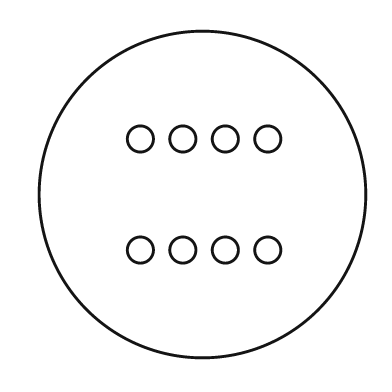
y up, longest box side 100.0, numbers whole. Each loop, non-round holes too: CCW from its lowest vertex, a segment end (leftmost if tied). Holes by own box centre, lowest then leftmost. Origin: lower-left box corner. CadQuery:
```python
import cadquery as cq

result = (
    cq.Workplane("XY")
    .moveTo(50.0, 50.0)
    .circle(50.0)
    .moveTo(31.0, 33.0)
    .circle(4.0)
    .moveTo(44.0, 33.0)
    .circle(4.0)
    .moveTo(57.0, 33.0)
    .circle(4.0)
    .moveTo(70.0, 33.0)
    .circle(4.0)
    .moveTo(31.0, 67.0)
    .circle(4.0)
    .moveTo(44.0, 67.0)
    .circle(4.0)
    .moveTo(57.0, 67.0)
    .circle(4.0)
    .moveTo(70.0, 67.0)
    .circle(4.0)
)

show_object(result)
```